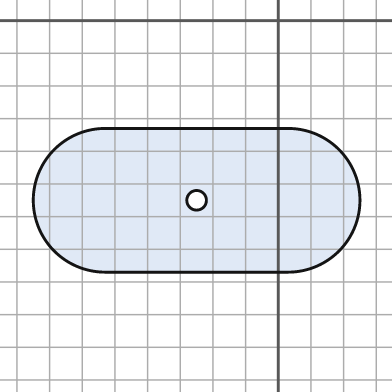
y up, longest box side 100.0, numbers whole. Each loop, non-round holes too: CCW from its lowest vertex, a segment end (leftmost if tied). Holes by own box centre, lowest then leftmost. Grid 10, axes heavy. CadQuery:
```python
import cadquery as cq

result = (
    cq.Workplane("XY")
    .moveTo(-53.0, -77.0)
    .lineTo(3.0, -77.0)
    .threePointArc((25.0, -55.0), (3.0, -33.0))
    .lineTo(-53.0, -33.0)
    .threePointArc((-75.0, -55.0), (-53.0, -77.0))
    .close()
    .moveTo(-25.0, -55.0)
    .circle(3.0)
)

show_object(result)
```